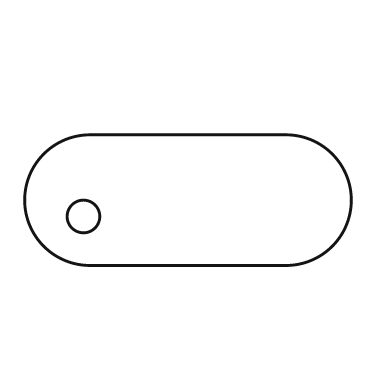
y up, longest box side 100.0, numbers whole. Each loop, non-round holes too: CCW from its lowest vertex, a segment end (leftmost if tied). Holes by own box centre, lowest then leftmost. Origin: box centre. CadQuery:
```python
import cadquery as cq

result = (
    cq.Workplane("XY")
    .moveTo(-30.0, -20.0)
    .lineTo(30.0, -20.0)
    .threePointArc((50.0, 0.0), (30.0, 20.0))
    .lineTo(-30.0, 20.0)
    .threePointArc((-50.0, 0.0), (-30.0, -20.0))
    .close()
    .moveTo(-32.0, -5.0)
    .circle(5.0)
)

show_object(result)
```